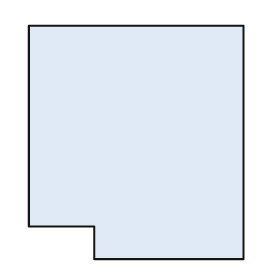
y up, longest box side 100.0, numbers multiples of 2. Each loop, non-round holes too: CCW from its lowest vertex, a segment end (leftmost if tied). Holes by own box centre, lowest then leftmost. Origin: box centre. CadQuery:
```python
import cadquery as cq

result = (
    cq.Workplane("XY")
    .moveTo(-18.0, -50.0)
    .lineTo(46.0, -50.0)
    .lineTo(46.0, 50.0)
    .lineTo(-46.0, 50.0)
    .lineTo(-46.0, -36.0)
    .lineTo(-18.0, -36.0)
    .close()
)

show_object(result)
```